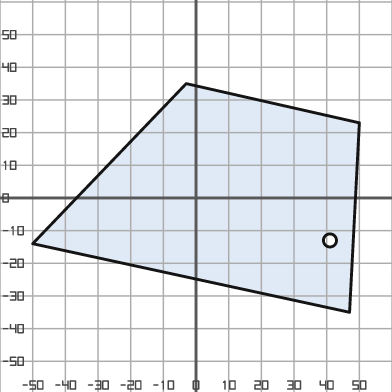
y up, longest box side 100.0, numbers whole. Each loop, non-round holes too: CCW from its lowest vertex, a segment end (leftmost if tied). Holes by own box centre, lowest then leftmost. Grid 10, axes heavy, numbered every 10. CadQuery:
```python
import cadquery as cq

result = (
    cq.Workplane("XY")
    .moveTo(47.0, -35.0)
    .lineTo(50.0, 23.0)
    .lineTo(-3.0, 35.0)
    .lineTo(-50.0, -14.0)
    .close()
    .moveTo(41.0, -13.0)
    .circle(2.0)
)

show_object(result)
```